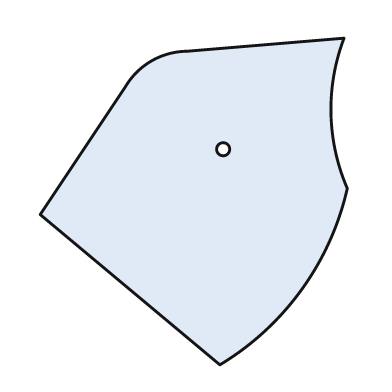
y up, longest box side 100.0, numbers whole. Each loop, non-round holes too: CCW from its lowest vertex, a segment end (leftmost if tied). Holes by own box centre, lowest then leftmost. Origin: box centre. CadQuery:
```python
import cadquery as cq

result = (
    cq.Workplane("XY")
    .moveTo(8.0, -50.0)
    .threePointArc((33.0, -27.0), (47.0, 4.0))
    .threePointArc((42.0, 27.0), (46.0, 50.0))
    .lineTo(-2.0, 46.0)
    .threePointArc((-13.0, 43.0), (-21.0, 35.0))
    .lineTo(-47.0, -4.0)
    .close()
    .moveTo(9.0, 16.0)
    .circle(2.0)
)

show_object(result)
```